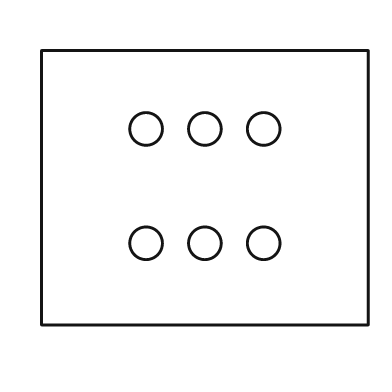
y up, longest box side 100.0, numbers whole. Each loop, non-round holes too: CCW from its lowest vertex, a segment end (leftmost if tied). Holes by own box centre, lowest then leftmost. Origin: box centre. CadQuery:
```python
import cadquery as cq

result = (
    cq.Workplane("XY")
    .moveTo(-50.0, -42.0)
    .lineTo(50.0, -42.0)
    .lineTo(50.0, 42.0)
    .lineTo(-50.0, 42.0)
    .close()
    .moveTo(-18.0, -17.0)
    .circle(5.0)
    .moveTo(0.0, -17.0)
    .circle(5.0)
    .moveTo(18.0, -17.0)
    .circle(5.0)
    .moveTo(-18.0, 18.0)
    .circle(5.0)
    .moveTo(0.0, 18.0)
    .circle(5.0)
    .moveTo(18.0, 18.0)
    .circle(5.0)
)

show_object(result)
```